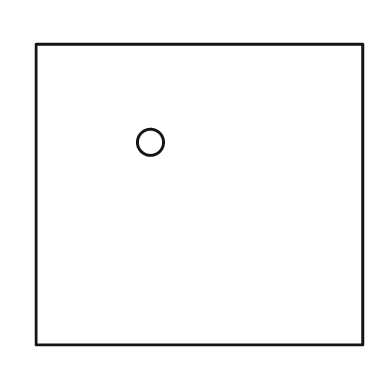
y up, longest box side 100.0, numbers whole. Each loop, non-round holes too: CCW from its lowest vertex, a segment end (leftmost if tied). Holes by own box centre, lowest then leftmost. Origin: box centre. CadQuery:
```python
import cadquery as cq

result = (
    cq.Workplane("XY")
    .moveTo(-50.0, -46.0)
    .lineTo(50.0, -46.0)
    .lineTo(50.0, 46.0)
    .lineTo(-50.0, 46.0)
    .close()
    .moveTo(-15.0, 16.0)
    .circle(4.0)
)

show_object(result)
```